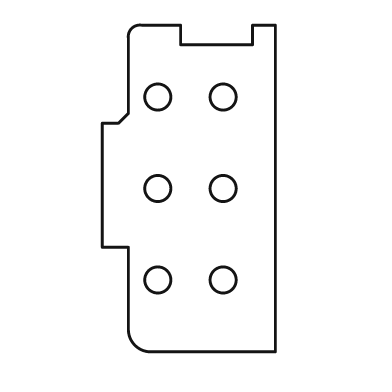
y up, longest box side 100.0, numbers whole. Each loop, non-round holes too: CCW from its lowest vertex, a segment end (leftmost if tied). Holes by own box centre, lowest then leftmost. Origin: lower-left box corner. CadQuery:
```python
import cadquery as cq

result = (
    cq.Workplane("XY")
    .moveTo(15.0, 0.0)
    .lineTo(53.0, 0.0)
    .lineTo(53.0, 100.0)
    .lineTo(46.0, 100.0)
    .lineTo(46.0, 94.0)
    .lineTo(24.0, 94.0)
    .lineTo(24.0, 100.0)
    .lineTo(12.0, 100.0)
    .threePointArc((9.0, 99.0), (8.0, 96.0))
    .lineTo(8.0, 73.0)
    .lineTo(5.0, 70.0)
    .lineTo(0.0, 70.0)
    .lineTo(0.0, 32.0)
    .lineTo(8.0, 32.0)
    .lineTo(8.0, 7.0)
    .threePointArc((10.0, 2.0), (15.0, 0.0))
    .close()
    .moveTo(17.0, 22.0)
    .circle(4.0)
    .moveTo(37.0, 22.0)
    .circle(4.0)
    .moveTo(17.0, 50.0)
    .circle(4.0)
    .moveTo(37.0, 50.0)
    .circle(4.0)
    .moveTo(17.0, 78.0)
    .circle(4.0)
    .moveTo(37.0, 78.0)
    .circle(4.0)
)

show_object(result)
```